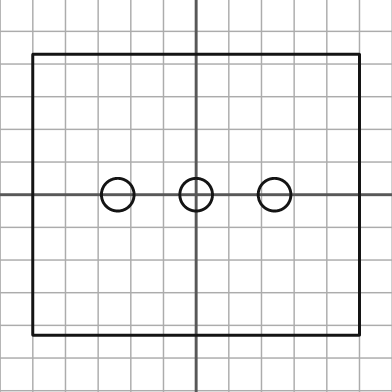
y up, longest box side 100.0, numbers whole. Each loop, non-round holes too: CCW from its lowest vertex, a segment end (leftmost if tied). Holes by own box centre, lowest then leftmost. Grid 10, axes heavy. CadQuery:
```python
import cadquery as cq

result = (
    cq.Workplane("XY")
    .moveTo(-50.0, -43.0)
    .lineTo(50.0, -43.0)
    .lineTo(50.0, 43.0)
    .lineTo(-50.0, 43.0)
    .close()
    .moveTo(-24.0, 0.0)
    .circle(5.0)
    .moveTo(0.0, 0.0)
    .circle(5.0)
    .moveTo(24.0, 0.0)
    .circle(5.0)
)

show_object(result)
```